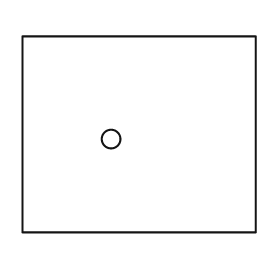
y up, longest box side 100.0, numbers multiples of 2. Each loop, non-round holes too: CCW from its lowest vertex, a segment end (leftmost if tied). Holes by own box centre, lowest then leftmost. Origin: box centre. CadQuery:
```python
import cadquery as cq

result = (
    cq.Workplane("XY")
    .moveTo(-50.0, -42.0)
    .lineTo(50.0, -42.0)
    .lineTo(50.0, 42.0)
    .lineTo(-50.0, 42.0)
    .close()
    .moveTo(-12.0, -2.0)
    .circle(4.0)
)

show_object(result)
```